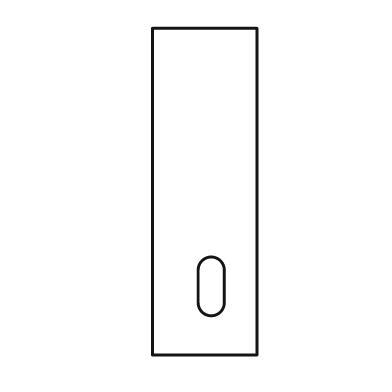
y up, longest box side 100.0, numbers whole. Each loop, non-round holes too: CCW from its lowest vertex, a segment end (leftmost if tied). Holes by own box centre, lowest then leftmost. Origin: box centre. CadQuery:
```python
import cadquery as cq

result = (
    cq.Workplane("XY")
    .moveTo(-16.0, -50.0)
    .lineTo(16.0, -50.0)
    .lineTo(16.0, 50.0)
    .lineTo(-16.0, 50.0)
    .close()
    .moveTo(-2.0, -34.0)
    .threePointArc((2.0, -38.0), (6.0, -34.0))
    .lineTo(6.0, -24.0)
    .threePointArc((2.0, -20.0), (-2.0, -24.0))
    .close()
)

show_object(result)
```